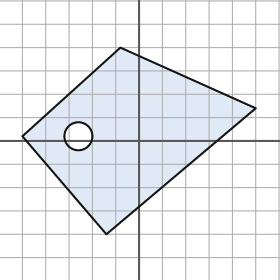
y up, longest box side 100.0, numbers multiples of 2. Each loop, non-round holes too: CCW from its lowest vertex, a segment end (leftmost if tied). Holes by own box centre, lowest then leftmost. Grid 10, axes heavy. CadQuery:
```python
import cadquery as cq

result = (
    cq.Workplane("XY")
    .moveTo(-14.0, -40.0)
    .lineTo(50.0, 14.0)
    .lineTo(-8.0, 40.0)
    .lineTo(-50.0, 2.0)
    .close()
    .moveTo(-26.0, 2.0)
    .circle(6.0)
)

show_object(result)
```